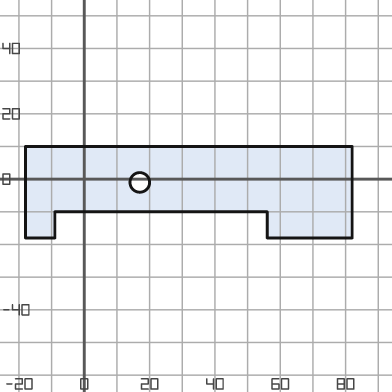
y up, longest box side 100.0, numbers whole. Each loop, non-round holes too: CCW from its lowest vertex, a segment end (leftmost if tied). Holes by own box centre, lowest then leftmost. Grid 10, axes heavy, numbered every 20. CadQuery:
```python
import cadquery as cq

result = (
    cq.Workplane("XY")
    .moveTo(-18.0, -18.0)
    .lineTo(-9.0, -18.0)
    .lineTo(-9.0, -10.0)
    .lineTo(56.0, -10.0)
    .lineTo(56.0, -18.0)
    .lineTo(82.0, -18.0)
    .lineTo(82.0, 10.0)
    .lineTo(-18.0, 10.0)
    .close()
    .moveTo(17.0, -1.0)
    .circle(3.0)
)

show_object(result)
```